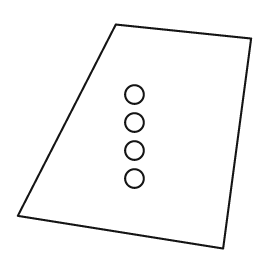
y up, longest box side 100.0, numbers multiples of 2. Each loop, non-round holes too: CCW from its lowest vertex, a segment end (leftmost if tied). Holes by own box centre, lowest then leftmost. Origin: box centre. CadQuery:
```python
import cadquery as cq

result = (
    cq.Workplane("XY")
    .moveTo(38.0, -48.0)
    .lineTo(50.0, 42.0)
    .lineTo(-8.0, 48.0)
    .lineTo(-50.0, -34.0)
    .close()
    .moveTo(0.0, -18.0)
    .circle(4.0)
    .moveTo(0.0, -6.0)
    .circle(4.0)
    .moveTo(0.0, 6.0)
    .circle(4.0)
    .moveTo(0.0, 18.0)
    .circle(4.0)
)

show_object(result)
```